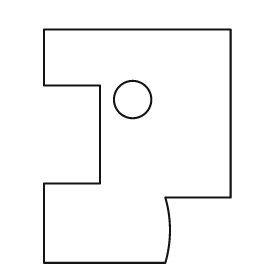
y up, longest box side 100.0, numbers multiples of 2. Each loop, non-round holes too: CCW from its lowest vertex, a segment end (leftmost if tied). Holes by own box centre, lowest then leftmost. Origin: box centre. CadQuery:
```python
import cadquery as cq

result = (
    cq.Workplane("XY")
    .moveTo(-40.0, -50.0)
    .lineTo(12.0, -50.0)
    .threePointArc((14.0, -36.0), (12.0, -22.0))
    .lineTo(40.0, -22.0)
    .lineTo(40.0, 50.0)
    .lineTo(-40.0, 50.0)
    .lineTo(-40.0, 26.0)
    .lineTo(-16.0, 26.0)
    .lineTo(-16.0, -16.0)
    .lineTo(-40.0, -16.0)
    .close()
    .moveTo(-2.0, 20.0)
    .circle(8.0)
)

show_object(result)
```